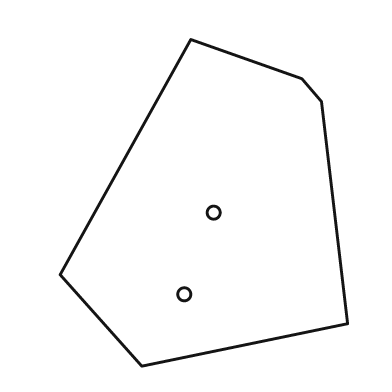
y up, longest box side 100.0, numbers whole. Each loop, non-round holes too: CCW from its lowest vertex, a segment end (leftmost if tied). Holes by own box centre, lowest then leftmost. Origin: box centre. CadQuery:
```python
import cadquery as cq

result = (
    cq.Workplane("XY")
    .moveTo(-19.0, -50.0)
    .lineTo(44.0, -37.0)
    .lineTo(36.0, 31.0)
    .lineTo(30.0, 38.0)
    .lineTo(-4.0, 50.0)
    .lineTo(-44.0, -22.0)
    .close()
    .moveTo(-6.0, -28.0)
    .circle(2.0)
    .moveTo(3.0, -3.0)
    .circle(2.0)
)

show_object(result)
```